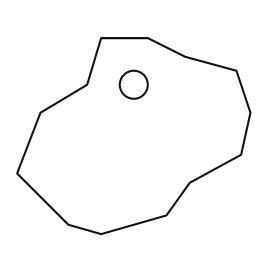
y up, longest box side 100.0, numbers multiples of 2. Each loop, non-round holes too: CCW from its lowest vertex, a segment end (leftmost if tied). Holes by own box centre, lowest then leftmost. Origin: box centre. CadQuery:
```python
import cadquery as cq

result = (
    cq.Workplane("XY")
    .moveTo(-14.0, -42.0)
    .lineTo(14.0, -34.0)
    .lineTo(24.0, -20.0)
    .lineTo(46.0, -8.0)
    .lineTo(50.0, 10.0)
    .lineTo(44.0, 28.0)
    .lineTo(22.0, 34.0)
    .lineTo(6.0, 42.0)
    .lineTo(-14.0, 42.0)
    .lineTo(-20.0, 22.0)
    .lineTo(-40.0, 10.0)
    .lineTo(-50.0, -16.0)
    .lineTo(-28.0, -38.0)
    .close()
    .moveTo(0.0, 22.0)
    .circle(6.0)
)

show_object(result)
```